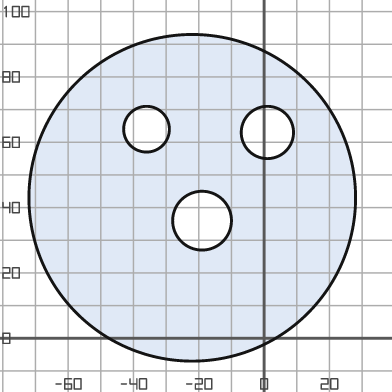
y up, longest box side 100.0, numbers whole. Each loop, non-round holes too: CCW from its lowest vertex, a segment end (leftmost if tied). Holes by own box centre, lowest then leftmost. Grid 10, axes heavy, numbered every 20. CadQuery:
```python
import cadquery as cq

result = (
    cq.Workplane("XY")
    .moveTo(-22.0, 43.0)
    .circle(50.0)
    .moveTo(-19.0, 36.0)
    .circle(9.0)
    .moveTo(1.0, 63.0)
    .circle(8.0)
    .moveTo(-36.0, 64.0)
    .circle(7.0)
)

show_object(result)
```